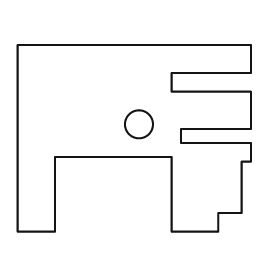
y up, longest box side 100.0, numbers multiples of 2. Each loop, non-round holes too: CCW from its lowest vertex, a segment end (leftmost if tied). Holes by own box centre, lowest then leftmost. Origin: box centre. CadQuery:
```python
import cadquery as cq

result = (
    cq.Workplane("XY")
    .moveTo(-50.0, -40.0)
    .lineTo(-34.0, -40.0)
    .lineTo(-34.0, -8.0)
    .lineTo(16.0, -8.0)
    .lineTo(16.0, -40.0)
    .lineTo(36.0, -40.0)
    .lineTo(36.0, -32.0)
    .lineTo(46.0, -32.0)
    .lineTo(46.0, -10.0)
    .lineTo(50.0, -10.0)
    .lineTo(50.0, -2.0)
    .lineTo(20.0, -2.0)
    .lineTo(20.0, 4.0)
    .lineTo(50.0, 4.0)
    .lineTo(50.0, 20.0)
    .lineTo(16.0, 20.0)
    .lineTo(16.0, 28.0)
    .lineTo(50.0, 28.0)
    .lineTo(50.0, 40.0)
    .lineTo(-50.0, 40.0)
    .close()
    .moveTo(2.0, 6.0)
    .circle(6.0)
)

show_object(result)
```